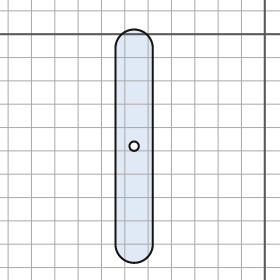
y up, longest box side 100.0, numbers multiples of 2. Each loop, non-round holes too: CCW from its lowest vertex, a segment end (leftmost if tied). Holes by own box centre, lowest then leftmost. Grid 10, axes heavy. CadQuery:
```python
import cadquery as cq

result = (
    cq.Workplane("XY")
    .moveTo(-64.0, -90.0)
    .threePointArc((-56.0, -98.0), (-48.0, -90.0))
    .lineTo(-48.0, -6.0)
    .threePointArc((-56.0, 2.0), (-64.0, -6.0))
    .close()
    .moveTo(-56.0, -48.0)
    .circle(2.0)
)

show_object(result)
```